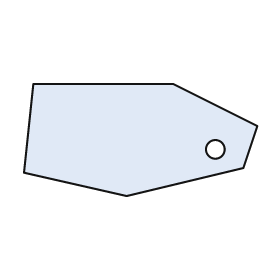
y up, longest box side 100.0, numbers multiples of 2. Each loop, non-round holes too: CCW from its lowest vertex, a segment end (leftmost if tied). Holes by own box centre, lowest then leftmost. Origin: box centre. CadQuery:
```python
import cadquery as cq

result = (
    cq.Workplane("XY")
    .moveTo(-6.0, -24.0)
    .lineTo(44.0, -12.0)
    .lineTo(50.0, 6.0)
    .lineTo(14.0, 24.0)
    .lineTo(-46.0, 24.0)
    .lineTo(-50.0, -14.0)
    .close()
    .moveTo(32.0, -4.0)
    .circle(4.0)
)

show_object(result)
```